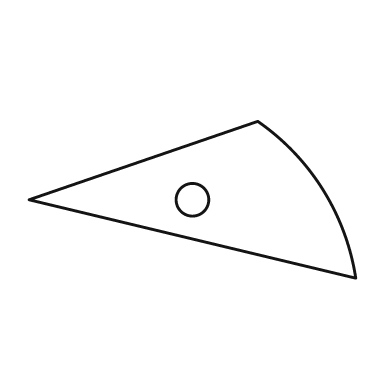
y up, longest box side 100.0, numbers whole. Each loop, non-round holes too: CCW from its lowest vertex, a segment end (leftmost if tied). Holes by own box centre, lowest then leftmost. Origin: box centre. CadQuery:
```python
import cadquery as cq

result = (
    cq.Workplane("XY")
    .moveTo(50.0, -24.0)
    .threePointArc((40.0, 3.0), (20.0, 24.0))
    .lineTo(-50.0, 0.0)
    .close()
    .moveTo(0.0, 0.0)
    .circle(5.0)
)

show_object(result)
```